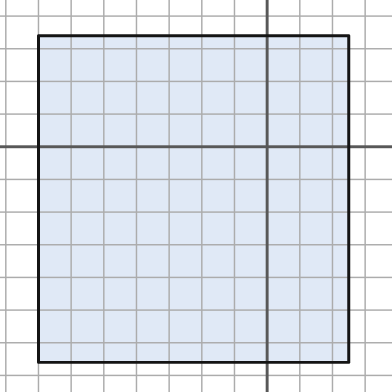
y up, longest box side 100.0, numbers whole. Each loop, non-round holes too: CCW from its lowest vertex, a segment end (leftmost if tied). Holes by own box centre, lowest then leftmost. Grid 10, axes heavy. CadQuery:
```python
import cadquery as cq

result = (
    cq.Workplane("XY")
    .moveTo(-70.0, -66.0)
    .lineTo(25.0, -66.0)
    .lineTo(25.0, 34.0)
    .lineTo(-70.0, 34.0)
    .close()
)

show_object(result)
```